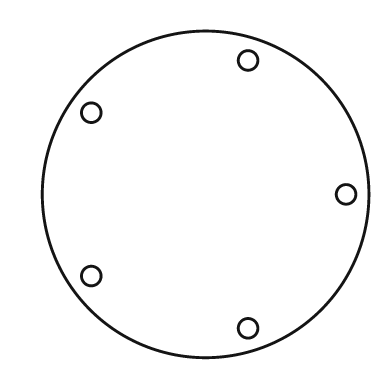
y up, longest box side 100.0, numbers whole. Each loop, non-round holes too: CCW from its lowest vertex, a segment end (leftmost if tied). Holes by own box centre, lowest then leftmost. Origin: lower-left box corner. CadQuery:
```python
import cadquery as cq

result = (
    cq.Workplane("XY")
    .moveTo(50.0, 50.0)
    .circle(50.0)
    .moveTo(63.0, 9.0)
    .circle(3.0)
    .moveTo(15.0, 25.0)
    .circle(3.0)
    .moveTo(93.0, 50.0)
    .circle(3.0)
    .moveTo(15.0, 75.0)
    .circle(3.0)
    .moveTo(63.0, 91.0)
    .circle(3.0)
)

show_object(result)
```